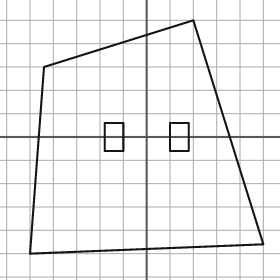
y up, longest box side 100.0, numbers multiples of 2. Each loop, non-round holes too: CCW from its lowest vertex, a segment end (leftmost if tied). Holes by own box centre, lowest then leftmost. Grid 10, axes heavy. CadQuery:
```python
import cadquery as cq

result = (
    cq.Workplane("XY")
    .moveTo(-50.0, -50.0)
    .lineTo(50.0, -46.0)
    .lineTo(20.0, 50.0)
    .lineTo(-44.0, 30.0)
    .close()
    .moveTo(-18.0, -6.0)
    .lineTo(-10.0, -6.0)
    .lineTo(-10.0, 6.0)
    .lineTo(-18.0, 6.0)
    .close()
    .moveTo(10.0, -6.0)
    .lineTo(18.0, -6.0)
    .lineTo(18.0, 6.0)
    .lineTo(10.0, 6.0)
    .close()
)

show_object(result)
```